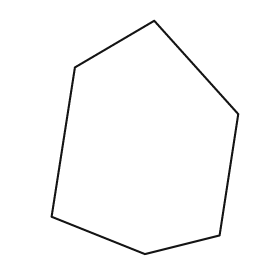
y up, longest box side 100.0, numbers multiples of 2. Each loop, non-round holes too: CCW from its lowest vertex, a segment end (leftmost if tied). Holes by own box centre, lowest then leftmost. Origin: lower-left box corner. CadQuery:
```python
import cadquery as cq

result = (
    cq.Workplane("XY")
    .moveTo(40.0, 0.0)
    .lineTo(72.0, 8.0)
    .lineTo(80.0, 60.0)
    .lineTo(44.0, 100.0)
    .lineTo(10.0, 80.0)
    .lineTo(0.0, 16.0)
    .close()
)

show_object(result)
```